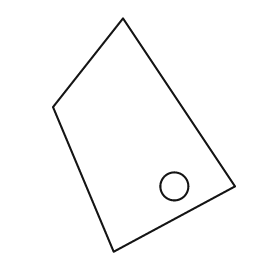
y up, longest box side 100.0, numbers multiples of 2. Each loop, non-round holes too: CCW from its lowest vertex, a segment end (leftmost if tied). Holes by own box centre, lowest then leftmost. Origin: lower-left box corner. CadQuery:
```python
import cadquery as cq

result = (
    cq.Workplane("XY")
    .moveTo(26.0, 0.0)
    .lineTo(78.0, 28.0)
    .lineTo(30.0, 100.0)
    .lineTo(0.0, 62.0)
    .close()
    .moveTo(52.0, 28.0)
    .circle(6.0)
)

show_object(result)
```